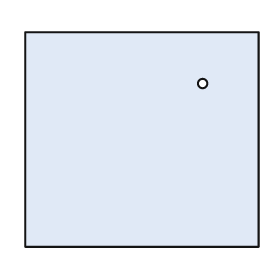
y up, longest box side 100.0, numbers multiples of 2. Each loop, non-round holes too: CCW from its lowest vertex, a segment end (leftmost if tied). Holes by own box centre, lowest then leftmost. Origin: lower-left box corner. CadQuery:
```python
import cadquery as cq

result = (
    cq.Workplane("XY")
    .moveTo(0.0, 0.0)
    .lineTo(100.0, 0.0)
    .lineTo(100.0, 92.0)
    .lineTo(0.0, 92.0)
    .close()
    .moveTo(76.0, 70.0)
    .circle(2.0)
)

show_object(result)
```